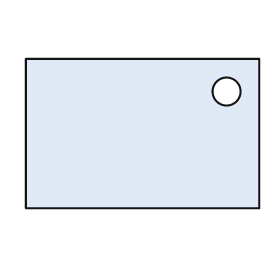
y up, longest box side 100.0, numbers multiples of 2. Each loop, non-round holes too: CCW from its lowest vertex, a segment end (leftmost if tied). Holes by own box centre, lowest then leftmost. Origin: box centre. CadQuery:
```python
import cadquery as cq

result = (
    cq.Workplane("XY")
    .moveTo(-50.0, -32.0)
    .lineTo(50.0, -32.0)
    .lineTo(50.0, 32.0)
    .lineTo(-50.0, 32.0)
    .close()
    .moveTo(36.0, 18.0)
    .circle(6.0)
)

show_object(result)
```